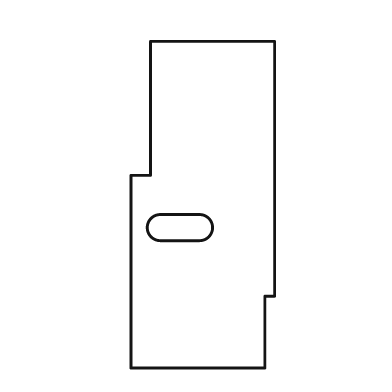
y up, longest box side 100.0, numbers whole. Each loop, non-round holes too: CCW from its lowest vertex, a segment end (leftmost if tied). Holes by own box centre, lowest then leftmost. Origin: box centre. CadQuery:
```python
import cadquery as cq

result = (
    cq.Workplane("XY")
    .moveTo(-22.0, -50.0)
    .lineTo(19.0, -50.0)
    .lineTo(19.0, -28.0)
    .lineTo(22.0, -28.0)
    .lineTo(22.0, 50.0)
    .lineTo(-16.0, 50.0)
    .lineTo(-16.0, 9.0)
    .lineTo(-22.0, 9.0)
    .close()
    .moveTo(-13.0, -11.0)
    .lineTo(-1.0, -11.0)
    .threePointArc((3.0, -7.0), (-1.0, -3.0))
    .lineTo(-13.0, -3.0)
    .threePointArc((-17.0, -7.0), (-13.0, -11.0))
    .close()
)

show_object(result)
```